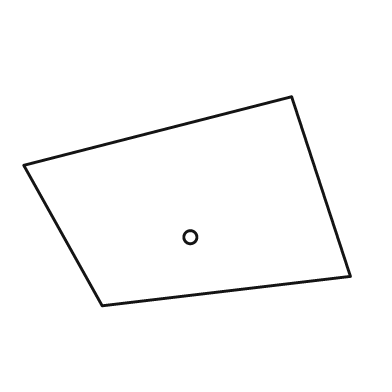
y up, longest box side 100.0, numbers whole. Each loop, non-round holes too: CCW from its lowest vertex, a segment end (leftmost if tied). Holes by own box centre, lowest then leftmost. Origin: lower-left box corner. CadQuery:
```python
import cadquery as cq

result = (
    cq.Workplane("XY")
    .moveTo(24.0, 0.0)
    .lineTo(100.0, 9.0)
    .lineTo(82.0, 64.0)
    .lineTo(0.0, 43.0)
    .close()
    .moveTo(51.0, 21.0)
    .circle(2.0)
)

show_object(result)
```